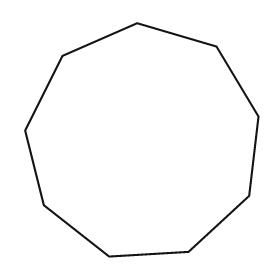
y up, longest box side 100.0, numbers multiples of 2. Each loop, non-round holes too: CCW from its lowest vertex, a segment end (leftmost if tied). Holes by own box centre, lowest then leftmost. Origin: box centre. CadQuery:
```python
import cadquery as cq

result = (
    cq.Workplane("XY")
    .moveTo(-14.0, -50.0)
    .lineTo(20.0, -48.0)
    .lineTo(46.0, -24.0)
    .lineTo(50.0, 10.0)
    .lineTo(32.0, 40.0)
    .lineTo(-2.0, 50.0)
    .lineTo(-34.0, 36.0)
    .lineTo(-50.0, 4.0)
    .lineTo(-42.0, -28.0)
    .close()
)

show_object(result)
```